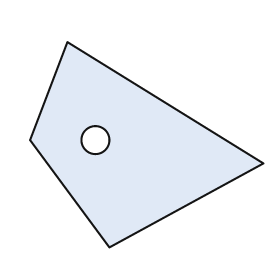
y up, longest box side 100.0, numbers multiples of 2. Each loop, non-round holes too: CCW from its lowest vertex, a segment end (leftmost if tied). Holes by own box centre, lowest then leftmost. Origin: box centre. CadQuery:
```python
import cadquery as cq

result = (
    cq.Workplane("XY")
    .moveTo(-16.0, -44.0)
    .lineTo(50.0, -8.0)
    .lineTo(-34.0, 44.0)
    .lineTo(-50.0, 2.0)
    .close()
    .moveTo(-22.0, 2.0)
    .circle(6.0)
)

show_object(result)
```